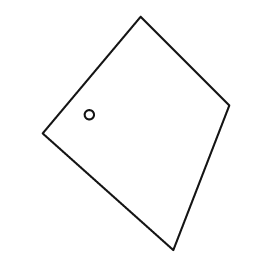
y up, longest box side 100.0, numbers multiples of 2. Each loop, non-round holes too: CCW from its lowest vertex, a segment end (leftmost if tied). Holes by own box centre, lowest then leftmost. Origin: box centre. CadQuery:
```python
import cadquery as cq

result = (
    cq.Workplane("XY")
    .moveTo(16.0, -50.0)
    .lineTo(40.0, 12.0)
    .lineTo(2.0, 50.0)
    .lineTo(-40.0, 0.0)
    .close()
    .moveTo(-20.0, 8.0)
    .circle(2.0)
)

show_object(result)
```